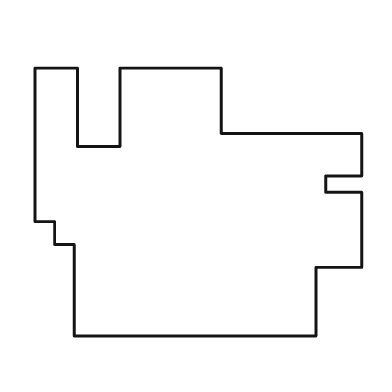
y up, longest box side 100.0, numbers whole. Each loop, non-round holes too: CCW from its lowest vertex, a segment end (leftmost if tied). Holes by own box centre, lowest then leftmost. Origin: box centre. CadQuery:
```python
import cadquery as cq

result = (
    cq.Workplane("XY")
    .moveTo(-38.0, -41.0)
    .lineTo(36.0, -41.0)
    .lineTo(36.0, -20.0)
    .lineTo(50.0, -20.0)
    .lineTo(50.0, 3.0)
    .lineTo(39.0, 3.0)
    .lineTo(39.0, 8.0)
    .lineTo(50.0, 8.0)
    .lineTo(50.0, 21.0)
    .lineTo(7.0, 21.0)
    .lineTo(7.0, 41.0)
    .lineTo(-24.0, 41.0)
    .lineTo(-24.0, 17.0)
    .lineTo(-37.0, 17.0)
    .lineTo(-37.0, 41.0)
    .lineTo(-50.0, 41.0)
    .lineTo(-50.0, -6.0)
    .lineTo(-44.0, -6.0)
    .lineTo(-44.0, -13.0)
    .lineTo(-38.0, -13.0)
    .close()
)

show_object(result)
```